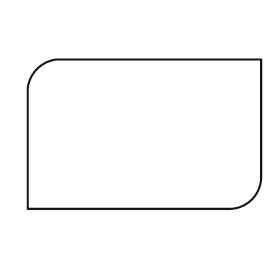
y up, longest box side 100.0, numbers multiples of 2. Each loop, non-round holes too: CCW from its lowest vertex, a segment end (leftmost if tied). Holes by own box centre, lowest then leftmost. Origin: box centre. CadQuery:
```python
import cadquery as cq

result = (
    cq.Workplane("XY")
    .moveTo(-50.0, -32.0)
    .lineTo(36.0, -32.0)
    .threePointArc((46.0, -28.0), (50.0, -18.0))
    .lineTo(50.0, 32.0)
    .lineTo(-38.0, 32.0)
    .threePointArc((-46.0, 28.0), (-50.0, 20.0))
    .close()
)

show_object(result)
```